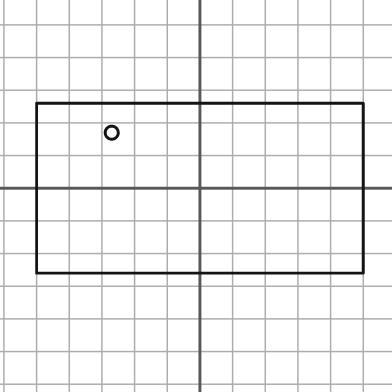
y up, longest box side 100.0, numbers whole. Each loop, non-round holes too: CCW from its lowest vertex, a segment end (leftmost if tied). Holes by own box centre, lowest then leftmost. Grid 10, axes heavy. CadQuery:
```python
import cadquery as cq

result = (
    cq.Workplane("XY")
    .moveTo(-50.0, -26.0)
    .lineTo(50.0, -26.0)
    .lineTo(50.0, 26.0)
    .lineTo(-50.0, 26.0)
    .close()
    .moveTo(-27.0, 17.0)
    .circle(2.0)
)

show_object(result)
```